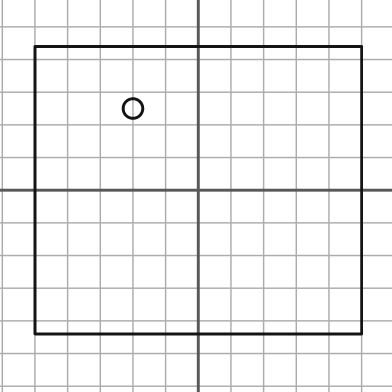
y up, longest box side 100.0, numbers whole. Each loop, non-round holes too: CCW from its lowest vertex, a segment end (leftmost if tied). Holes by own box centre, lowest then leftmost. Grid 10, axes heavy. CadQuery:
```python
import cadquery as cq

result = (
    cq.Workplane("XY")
    .moveTo(-50.0, -44.0)
    .lineTo(50.0, -44.0)
    .lineTo(50.0, 44.0)
    .lineTo(-50.0, 44.0)
    .close()
    .moveTo(-20.0, 25.0)
    .circle(3.0)
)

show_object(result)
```